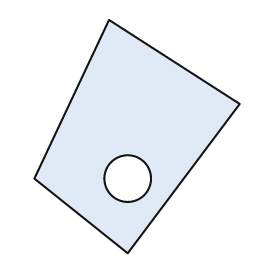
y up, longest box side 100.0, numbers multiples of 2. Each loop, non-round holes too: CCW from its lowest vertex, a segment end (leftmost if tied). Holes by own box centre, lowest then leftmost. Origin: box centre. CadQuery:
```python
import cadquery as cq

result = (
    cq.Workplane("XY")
    .moveTo(-4.0, -50.0)
    .lineTo(44.0, 14.0)
    .lineTo(-12.0, 50.0)
    .lineTo(-44.0, -18.0)
    .close()
    .moveTo(-4.0, -18.0)
    .circle(10.0)
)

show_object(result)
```